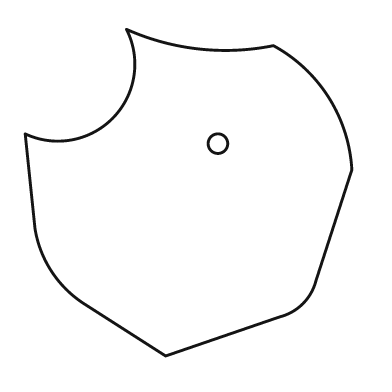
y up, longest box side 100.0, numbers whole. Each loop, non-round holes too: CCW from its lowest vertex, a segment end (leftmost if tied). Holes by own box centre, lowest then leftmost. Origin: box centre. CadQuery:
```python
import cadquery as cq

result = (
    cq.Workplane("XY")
    .moveTo(-7.0, -50.0)
    .lineTo(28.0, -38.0)
    .threePointArc((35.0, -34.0), (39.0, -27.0))
    .lineTo(50.0, 7.0)
    .threePointArc((43.0, 29.0), (26.0, 45.0))
    .threePointArc((3.0, 44.0), (-19.0, 50.0))
    .threePointArc((-23.0, 23.0), (-50.0, 18.0))
    .lineTo(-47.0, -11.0)
    .threePointArc((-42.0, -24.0), (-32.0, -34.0))
    .close()
    .moveTo(9.0, 15.0)
    .circle(3.0)
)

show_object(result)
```